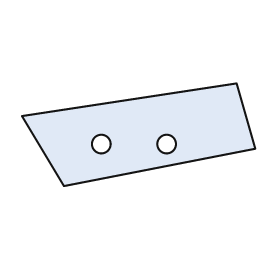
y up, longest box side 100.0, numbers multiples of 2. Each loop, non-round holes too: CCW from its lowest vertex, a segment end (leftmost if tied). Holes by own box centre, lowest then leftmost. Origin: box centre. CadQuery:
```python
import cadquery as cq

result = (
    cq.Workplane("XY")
    .moveTo(-32.0, -22.0)
    .lineTo(50.0, -6.0)
    .lineTo(42.0, 22.0)
    .lineTo(-50.0, 8.0)
    .close()
    .moveTo(-16.0, -4.0)
    .circle(4.0)
    .moveTo(12.0, -4.0)
    .circle(4.0)
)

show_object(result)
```